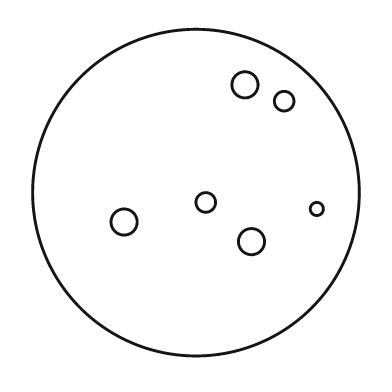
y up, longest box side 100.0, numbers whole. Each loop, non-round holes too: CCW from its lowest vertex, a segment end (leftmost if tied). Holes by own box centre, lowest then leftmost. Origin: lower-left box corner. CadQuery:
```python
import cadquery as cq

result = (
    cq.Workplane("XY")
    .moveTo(50.0, 50.0)
    .circle(50.0)
    .moveTo(67.0, 35.0)
    .circle(4.0)
    .moveTo(28.0, 41.0)
    .circle(4.0)
    .moveTo(87.0, 45.0)
    .circle(2.0)
    .moveTo(53.0, 47.0)
    .circle(3.0)
    .moveTo(77.0, 78.0)
    .circle(3.0)
    .moveTo(65.0, 83.0)
    .circle(4.0)
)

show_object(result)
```